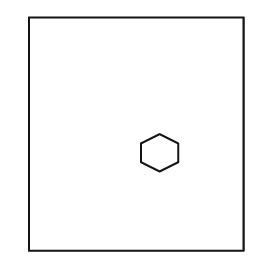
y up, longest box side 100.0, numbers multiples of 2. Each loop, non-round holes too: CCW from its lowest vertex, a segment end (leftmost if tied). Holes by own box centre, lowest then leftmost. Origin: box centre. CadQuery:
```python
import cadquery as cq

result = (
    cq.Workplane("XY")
    .moveTo(-46.0, -50.0)
    .lineTo(46.0, -50.0)
    .lineTo(46.0, 50.0)
    .lineTo(-46.0, 50.0)
    .close()
    .moveTo(10.0, -16.0)
    .lineTo(18.0, -12.0)
    .lineTo(18.0, -4.0)
    .lineTo(10.0, 0.0)
    .lineTo(2.0, -4.0)
    .lineTo(2.0, -12.0)
    .close()
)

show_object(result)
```